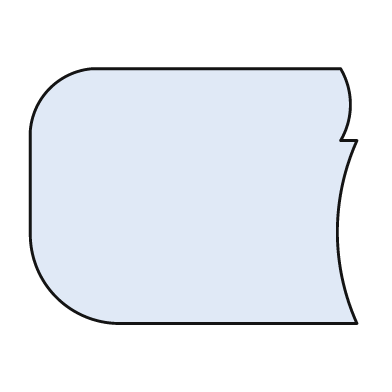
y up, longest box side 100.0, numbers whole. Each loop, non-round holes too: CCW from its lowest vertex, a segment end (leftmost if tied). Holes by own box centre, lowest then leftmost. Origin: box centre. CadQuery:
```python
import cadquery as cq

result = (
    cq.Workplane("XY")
    .moveTo(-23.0, -39.0)
    .lineTo(50.0, -39.0)
    .threePointArc((44.0, -11.0), (50.0, 17.0))
    .lineTo(45.0, 17.0)
    .threePointArc((48.0, 28.0), (45.0, 39.0))
    .lineTo(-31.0, 39.0)
    .threePointArc((-44.0, 33.0), (-50.0, 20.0))
    .lineTo(-50.0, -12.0)
    .threePointArc((-42.0, -31.0), (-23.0, -39.0))
    .close()
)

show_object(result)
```